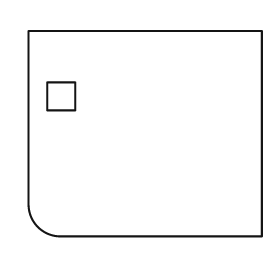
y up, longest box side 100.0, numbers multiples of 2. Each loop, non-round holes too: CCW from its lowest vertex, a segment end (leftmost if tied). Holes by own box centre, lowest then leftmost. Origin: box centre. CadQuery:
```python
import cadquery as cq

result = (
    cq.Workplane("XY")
    .moveTo(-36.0, -44.0)
    .lineTo(50.0, -44.0)
    .lineTo(50.0, 44.0)
    .lineTo(-50.0, 44.0)
    .lineTo(-50.0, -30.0)
    .threePointArc((-46.0, -40.0), (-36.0, -44.0))
    .close()
    .moveTo(-42.0, 10.0)
    .lineTo(-30.0, 10.0)
    .lineTo(-30.0, 22.0)
    .lineTo(-42.0, 22.0)
    .close()
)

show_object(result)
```